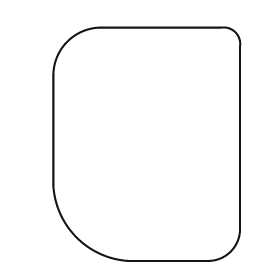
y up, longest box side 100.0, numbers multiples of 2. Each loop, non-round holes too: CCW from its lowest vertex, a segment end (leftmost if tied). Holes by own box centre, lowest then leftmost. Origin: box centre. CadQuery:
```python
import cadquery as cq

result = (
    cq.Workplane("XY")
    .moveTo(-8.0, -50.0)
    .lineTo(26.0, -50.0)
    .threePointArc((36.0, -46.0), (40.0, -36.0))
    .lineTo(40.0, 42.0)
    .threePointArc((38.0, 48.0), (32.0, 50.0))
    .lineTo(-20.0, 50.0)
    .threePointArc((-34.0, 44.0), (-40.0, 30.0))
    .lineTo(-40.0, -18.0)
    .threePointArc((-30.0, -40.0), (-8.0, -50.0))
    .close()
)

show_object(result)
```